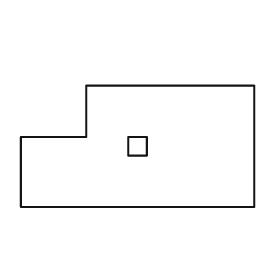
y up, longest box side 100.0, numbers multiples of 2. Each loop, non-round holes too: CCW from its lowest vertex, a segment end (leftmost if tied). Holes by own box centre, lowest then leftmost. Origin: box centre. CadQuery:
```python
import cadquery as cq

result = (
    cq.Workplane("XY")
    .moveTo(-50.0, -26.0)
    .lineTo(50.0, -26.0)
    .lineTo(50.0, 26.0)
    .lineTo(-22.0, 26.0)
    .lineTo(-22.0, 4.0)
    .lineTo(-50.0, 4.0)
    .close()
    .moveTo(-4.0, -4.0)
    .lineTo(4.0, -4.0)
    .lineTo(4.0, 4.0)
    .lineTo(-4.0, 4.0)
    .close()
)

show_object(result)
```